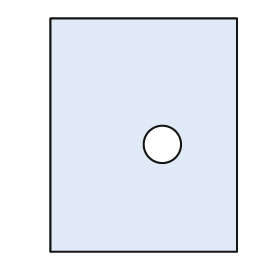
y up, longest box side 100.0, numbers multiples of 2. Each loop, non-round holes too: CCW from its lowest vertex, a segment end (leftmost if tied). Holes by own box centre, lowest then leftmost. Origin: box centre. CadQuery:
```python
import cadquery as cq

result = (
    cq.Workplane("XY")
    .moveTo(-40.0, -50.0)
    .lineTo(40.0, -50.0)
    .lineTo(40.0, 50.0)
    .lineTo(-40.0, 50.0)
    .close()
    .moveTo(8.0, -4.0)
    .circle(8.0)
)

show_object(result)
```